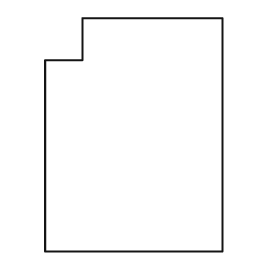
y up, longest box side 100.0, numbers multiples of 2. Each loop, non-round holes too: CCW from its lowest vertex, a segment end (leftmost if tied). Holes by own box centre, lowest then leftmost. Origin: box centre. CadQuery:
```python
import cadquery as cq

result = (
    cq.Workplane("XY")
    .moveTo(-38.0, -50.0)
    .lineTo(38.0, -50.0)
    .lineTo(38.0, 50.0)
    .lineTo(-22.0, 50.0)
    .lineTo(-22.0, 32.0)
    .lineTo(-38.0, 32.0)
    .close()
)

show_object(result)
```